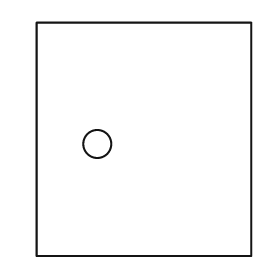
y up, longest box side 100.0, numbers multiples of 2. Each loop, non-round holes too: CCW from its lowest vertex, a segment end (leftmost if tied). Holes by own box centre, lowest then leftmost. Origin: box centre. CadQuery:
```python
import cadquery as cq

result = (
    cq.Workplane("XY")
    .moveTo(-46.0, -50.0)
    .lineTo(46.0, -50.0)
    .lineTo(46.0, 50.0)
    .lineTo(-46.0, 50.0)
    .close()
    .moveTo(-20.0, -2.0)
    .circle(6.0)
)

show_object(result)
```